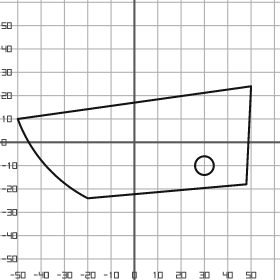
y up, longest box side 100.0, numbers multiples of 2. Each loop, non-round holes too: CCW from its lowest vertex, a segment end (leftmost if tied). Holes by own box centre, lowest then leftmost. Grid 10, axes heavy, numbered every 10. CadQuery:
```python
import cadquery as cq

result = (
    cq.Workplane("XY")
    .moveTo(-20.0, -24.0)
    .lineTo(48.0, -18.0)
    .lineTo(50.0, 24.0)
    .lineTo(-50.0, 10.0)
    .threePointArc((-38.0, -10.0), (-20.0, -24.0))
    .close()
    .moveTo(30.0, -10.0)
    .circle(4.0)
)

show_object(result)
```